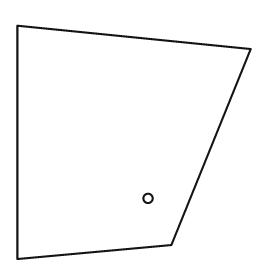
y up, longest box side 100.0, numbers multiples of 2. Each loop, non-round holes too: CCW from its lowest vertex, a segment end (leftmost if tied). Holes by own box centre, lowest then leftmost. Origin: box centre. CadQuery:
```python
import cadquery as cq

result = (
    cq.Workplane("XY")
    .moveTo(-50.0, -50.0)
    .lineTo(16.0, -44.0)
    .lineTo(50.0, 40.0)
    .lineTo(-50.0, 50.0)
    .close()
    .moveTo(6.0, -24.0)
    .circle(2.0)
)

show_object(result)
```